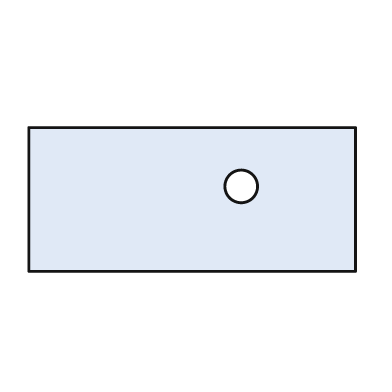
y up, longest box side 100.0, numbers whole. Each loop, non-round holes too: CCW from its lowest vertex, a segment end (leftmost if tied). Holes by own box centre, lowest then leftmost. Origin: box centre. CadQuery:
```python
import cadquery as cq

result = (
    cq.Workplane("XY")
    .moveTo(-50.0, -22.0)
    .lineTo(50.0, -22.0)
    .lineTo(50.0, 22.0)
    .lineTo(-50.0, 22.0)
    .close()
    .moveTo(15.0, 4.0)
    .circle(5.0)
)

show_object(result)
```